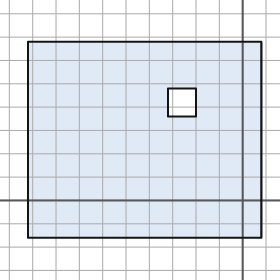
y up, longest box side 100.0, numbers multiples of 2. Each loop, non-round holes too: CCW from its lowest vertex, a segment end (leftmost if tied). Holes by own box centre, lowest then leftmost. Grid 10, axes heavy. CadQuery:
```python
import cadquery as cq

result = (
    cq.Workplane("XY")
    .moveTo(-92.0, -16.0)
    .lineTo(8.0, -16.0)
    .lineTo(8.0, 68.0)
    .lineTo(-92.0, 68.0)
    .close()
    .moveTo(-32.0, 36.0)
    .lineTo(-20.0, 36.0)
    .lineTo(-20.0, 48.0)
    .lineTo(-32.0, 48.0)
    .close()
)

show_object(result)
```